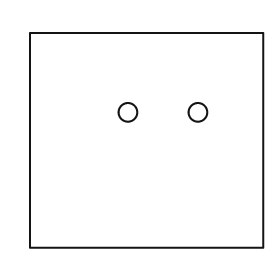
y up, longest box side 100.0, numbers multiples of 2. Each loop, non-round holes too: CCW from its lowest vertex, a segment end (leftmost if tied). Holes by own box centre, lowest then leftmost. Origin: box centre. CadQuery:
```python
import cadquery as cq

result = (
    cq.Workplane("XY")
    .moveTo(-50.0, -46.0)
    .lineTo(50.0, -46.0)
    .lineTo(50.0, 46.0)
    .lineTo(-50.0, 46.0)
    .close()
    .moveTo(-8.0, 12.0)
    .circle(4.0)
    .moveTo(22.0, 12.0)
    .circle(4.0)
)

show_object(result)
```